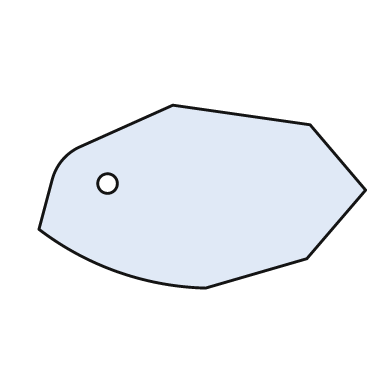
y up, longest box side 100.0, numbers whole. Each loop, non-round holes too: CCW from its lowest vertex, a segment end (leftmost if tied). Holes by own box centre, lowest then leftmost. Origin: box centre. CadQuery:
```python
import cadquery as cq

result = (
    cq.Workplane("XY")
    .moveTo(1.0, -28.0)
    .lineTo(32.0, -19.0)
    .lineTo(50.0, 2.0)
    .lineTo(33.0, 22.0)
    .lineTo(-9.0, 28.0)
    .lineTo(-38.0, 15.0)
    .threePointArc((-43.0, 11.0), (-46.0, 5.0))
    .lineTo(-50.0, -10.0)
    .threePointArc((-26.0, -23.0), (1.0, -28.0))
    .close()
    .moveTo(-29.0, 4.0)
    .circle(3.0)
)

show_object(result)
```